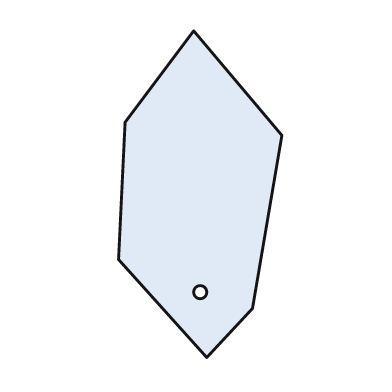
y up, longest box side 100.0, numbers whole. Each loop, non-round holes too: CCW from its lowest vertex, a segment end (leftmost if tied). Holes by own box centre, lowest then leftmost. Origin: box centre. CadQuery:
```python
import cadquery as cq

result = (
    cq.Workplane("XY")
    .moveTo(2.0, -50.0)
    .lineTo(16.0, -35.0)
    .lineTo(25.0, 18.0)
    .lineTo(-2.0, 50.0)
    .lineTo(-23.0, 22.0)
    .lineTo(-25.0, -20.0)
    .close()
    .moveTo(0.0, -30.0)
    .circle(2.0)
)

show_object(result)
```